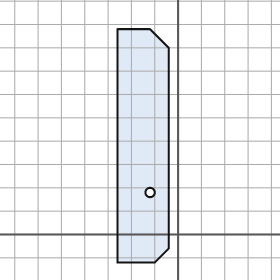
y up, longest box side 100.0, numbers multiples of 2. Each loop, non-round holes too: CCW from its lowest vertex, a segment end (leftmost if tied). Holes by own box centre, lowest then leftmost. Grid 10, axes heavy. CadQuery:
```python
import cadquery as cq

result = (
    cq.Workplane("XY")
    .moveTo(-26.0, -12.0)
    .lineTo(-10.0, -12.0)
    .lineTo(-4.0, -6.0)
    .lineTo(-4.0, 80.0)
    .lineTo(-12.0, 88.0)
    .lineTo(-26.0, 88.0)
    .close()
    .moveTo(-12.0, 18.0)
    .circle(2.0)
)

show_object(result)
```